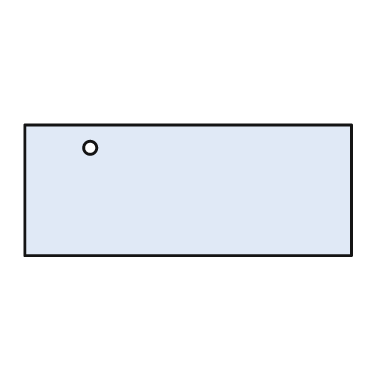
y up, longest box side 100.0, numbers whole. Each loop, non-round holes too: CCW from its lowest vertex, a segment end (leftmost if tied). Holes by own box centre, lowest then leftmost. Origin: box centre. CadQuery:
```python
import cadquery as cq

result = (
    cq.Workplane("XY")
    .moveTo(-50.0, -20.0)
    .lineTo(50.0, -20.0)
    .lineTo(50.0, 20.0)
    .lineTo(-50.0, 20.0)
    .close()
    .moveTo(-30.0, 13.0)
    .circle(2.0)
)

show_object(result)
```